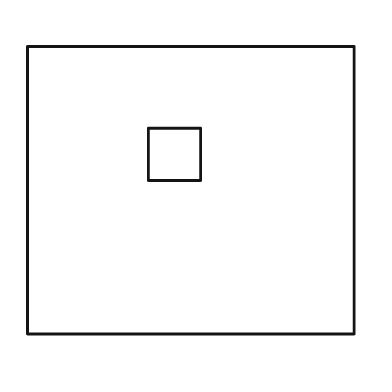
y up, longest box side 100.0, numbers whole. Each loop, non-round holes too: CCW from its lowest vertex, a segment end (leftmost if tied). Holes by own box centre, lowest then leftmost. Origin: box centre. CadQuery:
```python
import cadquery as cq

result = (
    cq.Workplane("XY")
    .moveTo(-50.0, -44.0)
    .lineTo(50.0, -44.0)
    .lineTo(50.0, 44.0)
    .lineTo(-50.0, 44.0)
    .close()
    .moveTo(-13.0, 3.0)
    .lineTo(3.0, 3.0)
    .lineTo(3.0, 19.0)
    .lineTo(-13.0, 19.0)
    .close()
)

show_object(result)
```